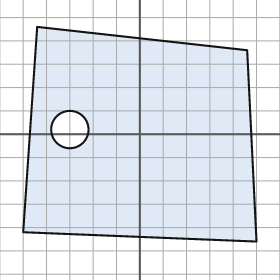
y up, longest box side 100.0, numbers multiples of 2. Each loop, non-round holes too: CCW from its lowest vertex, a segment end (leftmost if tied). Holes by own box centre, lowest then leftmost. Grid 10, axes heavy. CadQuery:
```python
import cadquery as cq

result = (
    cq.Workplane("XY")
    .moveTo(50.0, -46.0)
    .lineTo(46.0, 36.0)
    .lineTo(-44.0, 46.0)
    .lineTo(-50.0, -42.0)
    .close()
    .moveTo(-30.0, 2.0)
    .circle(8.0)
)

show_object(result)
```